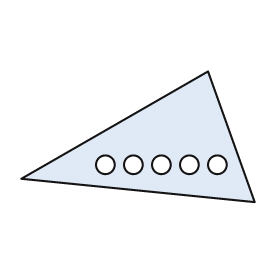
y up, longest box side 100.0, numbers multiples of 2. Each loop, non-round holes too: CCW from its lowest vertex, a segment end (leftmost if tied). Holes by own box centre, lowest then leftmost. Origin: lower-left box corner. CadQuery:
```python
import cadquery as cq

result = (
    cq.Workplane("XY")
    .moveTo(100.0, 0.0)
    .lineTo(80.0, 56.0)
    .lineTo(0.0, 10.0)
    .close()
    .moveTo(36.0, 16.0)
    .circle(4.0)
    .moveTo(48.0, 16.0)
    .circle(4.0)
    .moveTo(60.0, 16.0)
    .circle(4.0)
    .moveTo(72.0, 16.0)
    .circle(4.0)
    .moveTo(84.0, 16.0)
    .circle(4.0)
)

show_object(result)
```